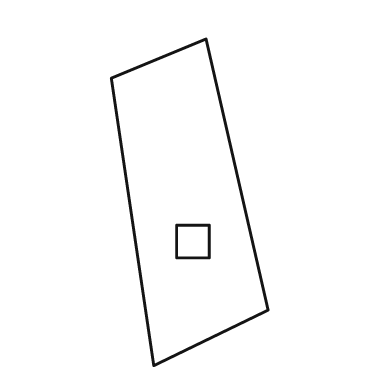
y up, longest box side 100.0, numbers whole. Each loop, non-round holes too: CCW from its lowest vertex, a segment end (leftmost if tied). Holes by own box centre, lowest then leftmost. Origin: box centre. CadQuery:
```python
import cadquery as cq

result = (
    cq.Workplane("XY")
    .moveTo(-11.0, -50.0)
    .lineTo(24.0, -33.0)
    .lineTo(5.0, 50.0)
    .lineTo(-24.0, 38.0)
    .close()
    .moveTo(-4.0, -17.0)
    .lineTo(6.0, -17.0)
    .lineTo(6.0, -7.0)
    .lineTo(-4.0, -7.0)
    .close()
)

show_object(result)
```